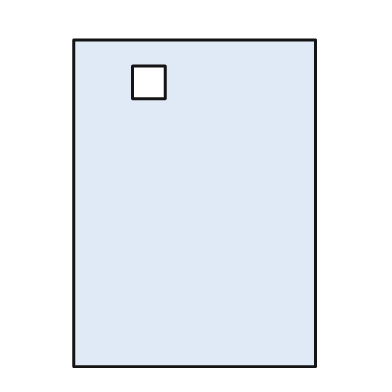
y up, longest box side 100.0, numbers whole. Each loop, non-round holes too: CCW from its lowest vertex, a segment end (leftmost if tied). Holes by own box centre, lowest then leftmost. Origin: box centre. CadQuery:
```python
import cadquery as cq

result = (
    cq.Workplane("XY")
    .moveTo(-37.0, -50.0)
    .lineTo(37.0, -50.0)
    .lineTo(37.0, 50.0)
    .lineTo(-37.0, 50.0)
    .close()
    .moveTo(-19.0, 32.0)
    .lineTo(-9.0, 32.0)
    .lineTo(-9.0, 42.0)
    .lineTo(-19.0, 42.0)
    .close()
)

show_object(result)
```